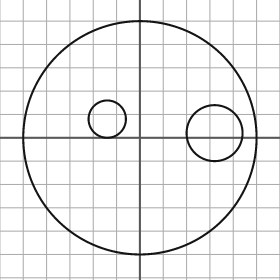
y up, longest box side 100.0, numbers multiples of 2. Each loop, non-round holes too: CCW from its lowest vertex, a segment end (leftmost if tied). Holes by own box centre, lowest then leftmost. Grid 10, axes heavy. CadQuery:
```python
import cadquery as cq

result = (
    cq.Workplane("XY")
    .moveTo(0.0, 0.0)
    .circle(50.0)
    .moveTo(32.0, 2.0)
    .circle(12.0)
    .moveTo(-14.0, 8.0)
    .circle(8.0)
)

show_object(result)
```